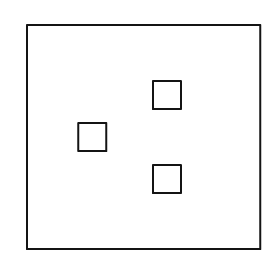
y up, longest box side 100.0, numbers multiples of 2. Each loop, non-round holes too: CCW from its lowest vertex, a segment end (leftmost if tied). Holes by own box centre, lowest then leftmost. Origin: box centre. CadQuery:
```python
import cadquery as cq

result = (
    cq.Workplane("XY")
    .moveTo(-50.0, -48.0)
    .lineTo(50.0, -48.0)
    .lineTo(50.0, 48.0)
    .lineTo(-50.0, 48.0)
    .close()
    .moveTo(4.0, -24.0)
    .lineTo(16.0, -24.0)
    .lineTo(16.0, -12.0)
    .lineTo(4.0, -12.0)
    .close()
    .moveTo(-28.0, -6.0)
    .lineTo(-16.0, -6.0)
    .lineTo(-16.0, 6.0)
    .lineTo(-28.0, 6.0)
    .close()
    .moveTo(4.0, 12.0)
    .lineTo(16.0, 12.0)
    .lineTo(16.0, 24.0)
    .lineTo(4.0, 24.0)
    .close()
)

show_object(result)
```